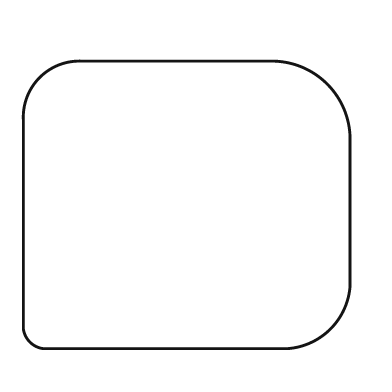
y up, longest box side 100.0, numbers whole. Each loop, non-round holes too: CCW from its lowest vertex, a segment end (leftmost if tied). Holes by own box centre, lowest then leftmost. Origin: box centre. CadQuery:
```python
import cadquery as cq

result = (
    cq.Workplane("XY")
    .moveTo(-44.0, -44.0)
    .lineTo(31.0, -44.0)
    .threePointArc((44.0, -38.0), (50.0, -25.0))
    .lineTo(50.0, 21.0)
    .threePointArc((43.0, 37.0), (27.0, 44.0))
    .lineTo(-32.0, 44.0)
    .threePointArc((-45.0, 39.0), (-50.0, 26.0))
    .lineTo(-50.0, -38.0)
    .threePointArc((-48.0, -42.0), (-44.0, -44.0))
    .close()
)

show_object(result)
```